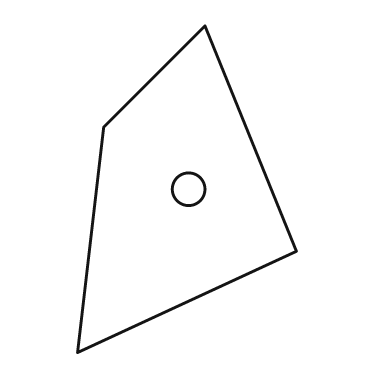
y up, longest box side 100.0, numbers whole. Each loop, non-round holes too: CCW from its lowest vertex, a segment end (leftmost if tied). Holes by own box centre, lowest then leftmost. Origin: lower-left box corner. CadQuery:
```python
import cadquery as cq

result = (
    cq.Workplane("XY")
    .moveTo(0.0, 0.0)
    .lineTo(67.0, 31.0)
    .lineTo(39.0, 100.0)
    .lineTo(8.0, 69.0)
    .close()
    .moveTo(34.0, 50.0)
    .circle(5.0)
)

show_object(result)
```